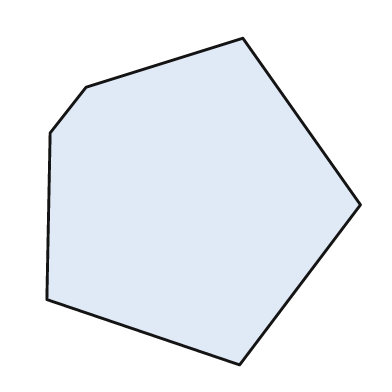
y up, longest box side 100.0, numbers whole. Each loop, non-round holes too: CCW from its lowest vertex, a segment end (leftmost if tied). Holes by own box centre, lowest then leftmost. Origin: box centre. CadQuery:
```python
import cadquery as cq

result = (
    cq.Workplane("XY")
    .moveTo(11.0, -50.0)
    .lineTo(48.0, -1.0)
    .lineTo(12.0, 50.0)
    .lineTo(-36.0, 35.0)
    .lineTo(-47.0, 21.0)
    .lineTo(-48.0, -30.0)
    .close()
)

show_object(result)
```